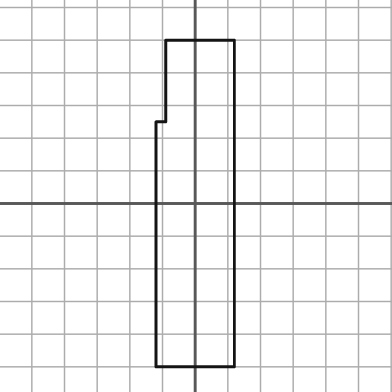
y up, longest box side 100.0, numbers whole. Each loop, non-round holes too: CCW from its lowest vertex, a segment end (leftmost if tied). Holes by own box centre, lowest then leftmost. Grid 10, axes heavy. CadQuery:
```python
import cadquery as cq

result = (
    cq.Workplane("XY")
    .moveTo(-12.0, -50.0)
    .lineTo(12.0, -50.0)
    .lineTo(12.0, 50.0)
    .lineTo(-9.0, 50.0)
    .lineTo(-9.0, 25.0)
    .lineTo(-12.0, 25.0)
    .close()
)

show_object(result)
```